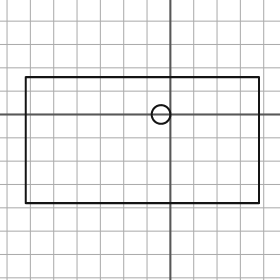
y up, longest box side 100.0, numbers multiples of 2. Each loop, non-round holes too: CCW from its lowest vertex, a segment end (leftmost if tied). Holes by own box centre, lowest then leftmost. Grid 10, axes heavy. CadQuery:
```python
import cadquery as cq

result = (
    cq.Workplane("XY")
    .moveTo(-62.0, -38.0)
    .lineTo(38.0, -38.0)
    .lineTo(38.0, 16.0)
    .lineTo(-62.0, 16.0)
    .close()
    .moveTo(-4.0, 0.0)
    .circle(4.0)
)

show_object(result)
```